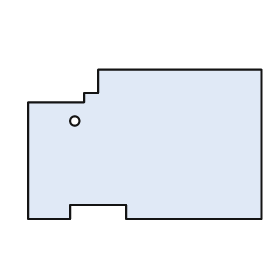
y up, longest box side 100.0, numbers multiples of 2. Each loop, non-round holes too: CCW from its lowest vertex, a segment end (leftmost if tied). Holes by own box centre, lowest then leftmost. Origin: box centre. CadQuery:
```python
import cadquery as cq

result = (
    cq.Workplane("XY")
    .moveTo(-50.0, -32.0)
    .lineTo(-32.0, -32.0)
    .lineTo(-32.0, -26.0)
    .lineTo(-8.0, -26.0)
    .lineTo(-8.0, -32.0)
    .lineTo(50.0, -32.0)
    .lineTo(50.0, 32.0)
    .lineTo(-20.0, 32.0)
    .lineTo(-20.0, 22.0)
    .lineTo(-26.0, 22.0)
    .lineTo(-26.0, 18.0)
    .lineTo(-50.0, 18.0)
    .close()
    .moveTo(-30.0, 10.0)
    .circle(2.0)
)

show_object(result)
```